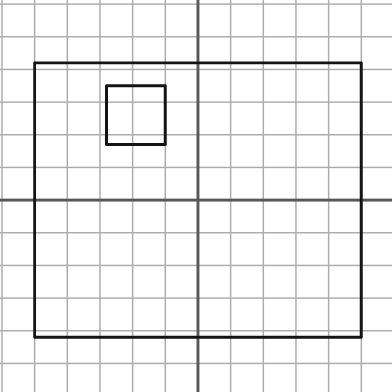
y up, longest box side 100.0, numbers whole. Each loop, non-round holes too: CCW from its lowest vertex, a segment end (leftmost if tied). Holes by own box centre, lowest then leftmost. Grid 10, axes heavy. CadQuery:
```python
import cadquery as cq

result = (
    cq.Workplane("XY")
    .moveTo(-50.0, -42.0)
    .lineTo(50.0, -42.0)
    .lineTo(50.0, 42.0)
    .lineTo(-50.0, 42.0)
    .close()
    .moveTo(-28.0, 17.0)
    .lineTo(-10.0, 17.0)
    .lineTo(-10.0, 35.0)
    .lineTo(-28.0, 35.0)
    .close()
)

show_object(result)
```